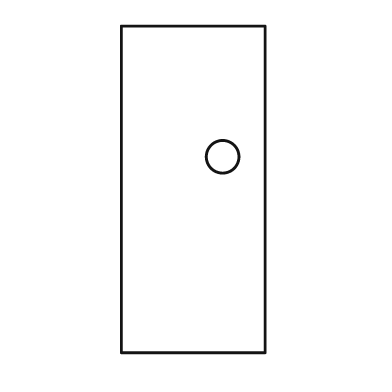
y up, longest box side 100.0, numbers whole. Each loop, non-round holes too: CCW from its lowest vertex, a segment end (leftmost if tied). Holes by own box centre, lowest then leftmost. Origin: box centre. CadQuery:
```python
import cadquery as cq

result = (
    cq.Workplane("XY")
    .moveTo(-22.0, -50.0)
    .lineTo(22.0, -50.0)
    .lineTo(22.0, 50.0)
    .lineTo(-22.0, 50.0)
    .close()
    .moveTo(9.0, 10.0)
    .circle(5.0)
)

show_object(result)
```